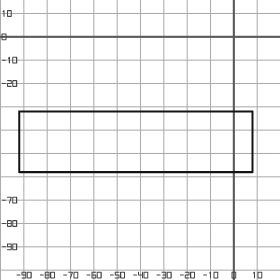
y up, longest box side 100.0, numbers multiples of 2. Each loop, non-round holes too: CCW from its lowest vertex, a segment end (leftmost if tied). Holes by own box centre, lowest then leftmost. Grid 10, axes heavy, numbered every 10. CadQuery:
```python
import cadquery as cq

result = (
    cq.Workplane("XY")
    .moveTo(-92.0, -58.0)
    .lineTo(8.0, -58.0)
    .lineTo(8.0, -32.0)
    .lineTo(-92.0, -32.0)
    .close()
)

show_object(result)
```